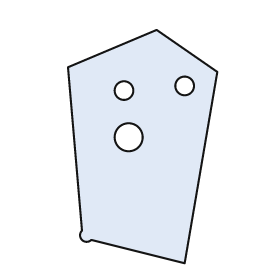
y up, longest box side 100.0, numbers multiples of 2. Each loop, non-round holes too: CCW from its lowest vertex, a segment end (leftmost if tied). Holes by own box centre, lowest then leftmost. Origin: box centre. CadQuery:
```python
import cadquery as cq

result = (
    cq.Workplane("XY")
    .moveTo(18.0, -50.0)
    .lineTo(32.0, 32.0)
    .lineTo(6.0, 50.0)
    .lineTo(-32.0, 34.0)
    .lineTo(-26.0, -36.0)
    .threePointArc((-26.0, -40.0), (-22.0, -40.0))
    .close()
    .moveTo(-6.0, 4.0)
    .circle(6.0)
    .moveTo(-8.0, 24.0)
    .circle(4.0)
    .moveTo(18.0, 26.0)
    .circle(4.0)
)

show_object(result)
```